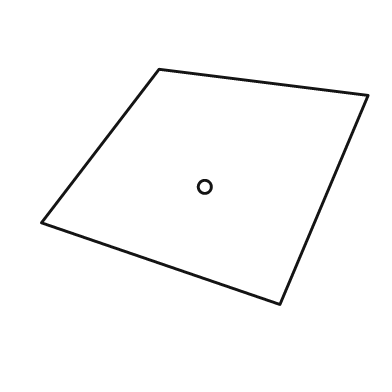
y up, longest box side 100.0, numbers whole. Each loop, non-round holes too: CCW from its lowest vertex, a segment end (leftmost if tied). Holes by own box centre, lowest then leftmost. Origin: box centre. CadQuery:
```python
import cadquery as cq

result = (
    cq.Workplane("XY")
    .moveTo(23.0, -36.0)
    .lineTo(50.0, 28.0)
    .lineTo(-14.0, 36.0)
    .lineTo(-50.0, -11.0)
    .close()
    .moveTo(0.0, 0.0)
    .circle(2.0)
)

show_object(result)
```